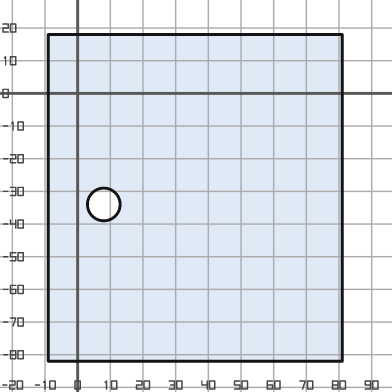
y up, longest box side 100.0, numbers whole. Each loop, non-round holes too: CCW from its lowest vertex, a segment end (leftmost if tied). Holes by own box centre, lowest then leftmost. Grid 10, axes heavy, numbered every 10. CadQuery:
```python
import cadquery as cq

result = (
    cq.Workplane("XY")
    .moveTo(-9.0, -82.0)
    .lineTo(81.0, -82.0)
    .lineTo(81.0, 18.0)
    .lineTo(-9.0, 18.0)
    .close()
    .moveTo(8.0, -34.0)
    .circle(5.0)
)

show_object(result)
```